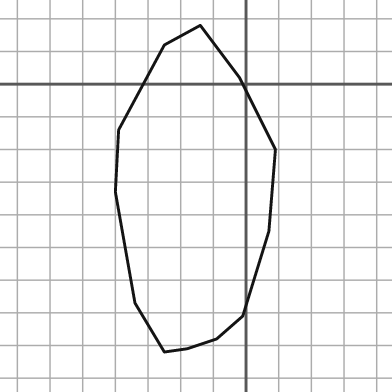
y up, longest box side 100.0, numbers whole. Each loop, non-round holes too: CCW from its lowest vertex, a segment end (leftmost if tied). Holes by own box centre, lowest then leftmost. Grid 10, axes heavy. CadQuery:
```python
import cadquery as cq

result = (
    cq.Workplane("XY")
    .moveTo(-25.0, -82.0)
    .lineTo(-18.0, -81.0)
    .lineTo(-9.0, -78.0)
    .lineTo(-1.0, -71.0)
    .lineTo(7.0, -45.0)
    .lineTo(9.0, -20.0)
    .lineTo(-2.0, 2.0)
    .lineTo(-14.0, 18.0)
    .lineTo(-25.0, 12.0)
    .lineTo(-39.0, -14.0)
    .lineTo(-40.0, -33.0)
    .lineTo(-34.0, -67.0)
    .close()
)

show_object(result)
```